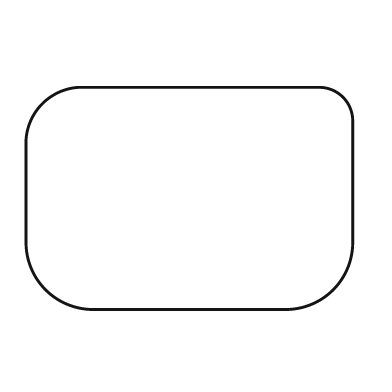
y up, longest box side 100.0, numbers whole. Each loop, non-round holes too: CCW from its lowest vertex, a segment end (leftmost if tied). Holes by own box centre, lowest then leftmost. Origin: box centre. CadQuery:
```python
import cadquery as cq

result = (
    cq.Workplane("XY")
    .moveTo(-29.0, -34.0)
    .lineTo(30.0, -34.0)
    .threePointArc((44.0, -28.0), (50.0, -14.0))
    .lineTo(50.0, 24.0)
    .threePointArc((47.0, 31.0), (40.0, 34.0))
    .lineTo(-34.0, 34.0)
    .threePointArc((-45.0, 29.0), (-50.0, 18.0))
    .lineTo(-50.0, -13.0)
    .threePointArc((-44.0, -28.0), (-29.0, -34.0))
    .close()
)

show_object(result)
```